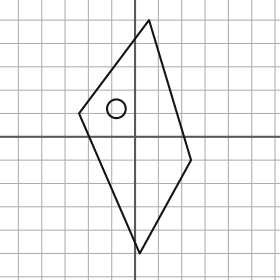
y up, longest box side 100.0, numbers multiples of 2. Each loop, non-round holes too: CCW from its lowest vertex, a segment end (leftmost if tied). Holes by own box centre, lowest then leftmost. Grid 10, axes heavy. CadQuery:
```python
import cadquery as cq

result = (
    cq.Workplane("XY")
    .moveTo(2.0, -50.0)
    .lineTo(24.0, -10.0)
    .lineTo(6.0, 50.0)
    .lineTo(-24.0, 10.0)
    .close()
    .moveTo(-8.0, 12.0)
    .circle(4.0)
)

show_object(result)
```